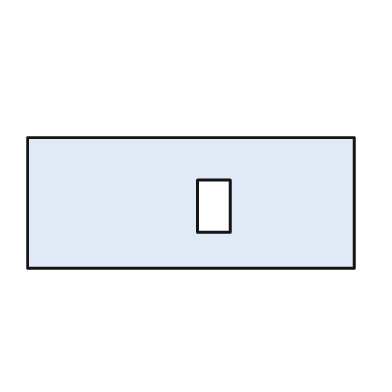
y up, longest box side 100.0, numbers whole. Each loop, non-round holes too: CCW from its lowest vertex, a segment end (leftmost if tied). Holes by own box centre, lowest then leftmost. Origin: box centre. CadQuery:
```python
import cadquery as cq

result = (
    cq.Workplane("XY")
    .moveTo(-50.0, -20.0)
    .lineTo(50.0, -20.0)
    .lineTo(50.0, 20.0)
    .lineTo(-50.0, 20.0)
    .close()
    .moveTo(2.0, -9.0)
    .lineTo(12.0, -9.0)
    .lineTo(12.0, 7.0)
    .lineTo(2.0, 7.0)
    .close()
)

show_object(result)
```